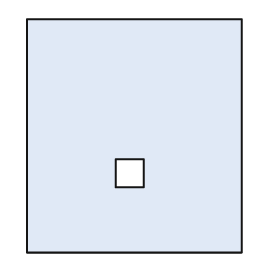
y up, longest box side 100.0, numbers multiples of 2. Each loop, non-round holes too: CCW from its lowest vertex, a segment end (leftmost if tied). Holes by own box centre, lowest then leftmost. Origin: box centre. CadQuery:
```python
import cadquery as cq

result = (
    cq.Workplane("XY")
    .moveTo(-46.0, -50.0)
    .lineTo(46.0, -50.0)
    .lineTo(46.0, 50.0)
    .lineTo(-46.0, 50.0)
    .close()
    .moveTo(-8.0, -22.0)
    .lineTo(4.0, -22.0)
    .lineTo(4.0, -10.0)
    .lineTo(-8.0, -10.0)
    .close()
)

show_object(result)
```